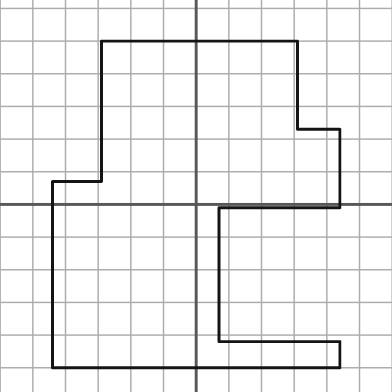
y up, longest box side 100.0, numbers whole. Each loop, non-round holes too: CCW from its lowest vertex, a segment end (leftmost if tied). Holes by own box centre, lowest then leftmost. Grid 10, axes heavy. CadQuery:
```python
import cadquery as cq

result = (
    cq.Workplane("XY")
    .moveTo(-44.0, -50.0)
    .lineTo(44.0, -50.0)
    .lineTo(44.0, -42.0)
    .lineTo(7.0, -42.0)
    .lineTo(7.0, -1.0)
    .lineTo(44.0, -1.0)
    .lineTo(44.0, 23.0)
    .lineTo(31.0, 23.0)
    .lineTo(31.0, 50.0)
    .lineTo(-29.0, 50.0)
    .lineTo(-29.0, 7.0)
    .lineTo(-44.0, 7.0)
    .close()
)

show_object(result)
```